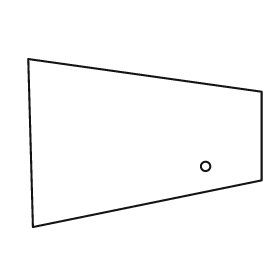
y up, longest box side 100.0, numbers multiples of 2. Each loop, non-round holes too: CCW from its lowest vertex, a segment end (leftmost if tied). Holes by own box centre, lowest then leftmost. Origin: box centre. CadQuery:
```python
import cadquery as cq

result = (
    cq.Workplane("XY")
    .moveTo(-48.0, -36.0)
    .lineTo(50.0, -16.0)
    .lineTo(50.0, 22.0)
    .lineTo(-50.0, 36.0)
    .close()
    .moveTo(26.0, -10.0)
    .circle(2.0)
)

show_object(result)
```